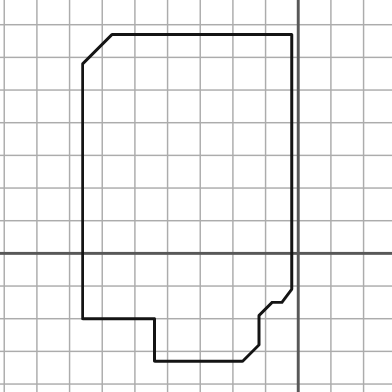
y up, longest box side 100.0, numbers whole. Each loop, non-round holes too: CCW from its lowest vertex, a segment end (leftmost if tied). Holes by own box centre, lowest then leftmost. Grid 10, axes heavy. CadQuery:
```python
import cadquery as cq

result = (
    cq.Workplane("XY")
    .moveTo(-44.0, -33.0)
    .lineTo(-17.0, -33.0)
    .lineTo(-12.0, -28.0)
    .lineTo(-12.0, -19.0)
    .lineTo(-8.0, -15.0)
    .lineTo(-5.0, -15.0)
    .lineTo(-2.0, -11.0)
    .lineTo(-2.0, 67.0)
    .lineTo(-57.0, 67.0)
    .lineTo(-66.0, 58.0)
    .lineTo(-66.0, -20.0)
    .lineTo(-44.0, -20.0)
    .close()
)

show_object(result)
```